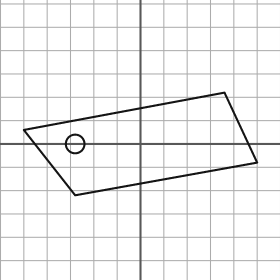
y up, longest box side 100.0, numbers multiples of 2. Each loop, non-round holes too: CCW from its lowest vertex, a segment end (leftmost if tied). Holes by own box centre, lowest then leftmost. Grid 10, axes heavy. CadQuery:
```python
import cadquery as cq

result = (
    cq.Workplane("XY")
    .moveTo(-28.0, -22.0)
    .lineTo(50.0, -8.0)
    .lineTo(36.0, 22.0)
    .lineTo(-50.0, 6.0)
    .close()
    .moveTo(-28.0, 0.0)
    .circle(4.0)
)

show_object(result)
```